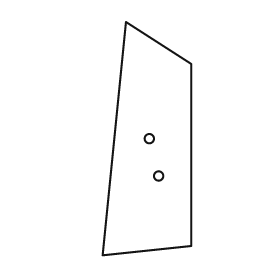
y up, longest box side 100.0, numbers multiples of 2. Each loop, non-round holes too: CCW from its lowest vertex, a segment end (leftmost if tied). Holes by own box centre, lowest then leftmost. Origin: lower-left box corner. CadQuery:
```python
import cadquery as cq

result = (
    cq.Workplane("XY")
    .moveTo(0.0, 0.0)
    .lineTo(38.0, 4.0)
    .lineTo(38.0, 82.0)
    .lineTo(10.0, 100.0)
    .close()
    .moveTo(24.0, 34.0)
    .circle(2.0)
    .moveTo(20.0, 50.0)
    .circle(2.0)
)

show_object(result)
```